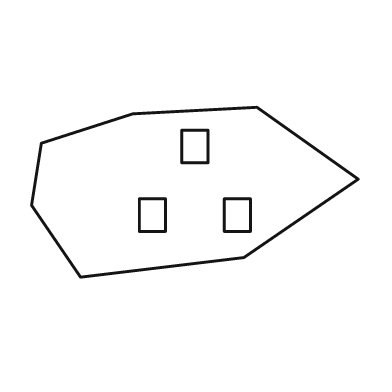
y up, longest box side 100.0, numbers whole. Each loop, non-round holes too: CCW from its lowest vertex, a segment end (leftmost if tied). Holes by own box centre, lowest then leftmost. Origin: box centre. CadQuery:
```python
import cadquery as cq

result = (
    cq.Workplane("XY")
    .moveTo(-35.0, -26.0)
    .lineTo(15.0, -20.0)
    .lineTo(50.0, 4.0)
    .lineTo(19.0, 26.0)
    .lineTo(-19.0, 24.0)
    .lineTo(-47.0, 15.0)
    .lineTo(-50.0, -4.0)
    .close()
    .moveTo(-17.0, -12.0)
    .lineTo(-9.0, -12.0)
    .lineTo(-9.0, -2.0)
    .lineTo(-17.0, -2.0)
    .close()
    .moveTo(9.0, -12.0)
    .lineTo(17.0, -12.0)
    .lineTo(17.0, -2.0)
    .lineTo(9.0, -2.0)
    .close()
    .moveTo(-4.0, 9.0)
    .lineTo(4.0, 9.0)
    .lineTo(4.0, 19.0)
    .lineTo(-4.0, 19.0)
    .close()
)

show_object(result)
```